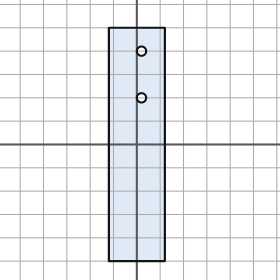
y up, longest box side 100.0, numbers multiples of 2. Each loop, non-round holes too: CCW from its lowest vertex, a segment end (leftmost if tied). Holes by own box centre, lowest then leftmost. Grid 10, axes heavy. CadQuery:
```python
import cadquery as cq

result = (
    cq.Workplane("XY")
    .moveTo(-12.0, -50.0)
    .lineTo(12.0, -50.0)
    .lineTo(12.0, 50.0)
    .lineTo(-12.0, 50.0)
    .close()
    .moveTo(2.0, 20.0)
    .circle(2.0)
    .moveTo(2.0, 40.0)
    .circle(2.0)
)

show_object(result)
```